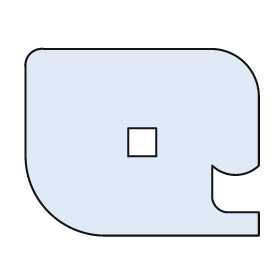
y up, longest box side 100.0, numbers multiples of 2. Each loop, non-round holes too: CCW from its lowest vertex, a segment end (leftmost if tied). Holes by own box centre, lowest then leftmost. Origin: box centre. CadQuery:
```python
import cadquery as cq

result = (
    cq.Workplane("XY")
    .moveTo(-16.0, -40.0)
    .lineTo(50.0, -40.0)
    .lineTo(50.0, -30.0)
    .lineTo(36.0, -30.0)
    .threePointArc((32.0, -28.0), (30.0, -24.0))
    .lineTo(30.0, -10.0)
    .threePointArc((40.0, -14.0), (50.0, -10.0))
    .lineTo(50.0, 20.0)
    .threePointArc((44.0, 34.0), (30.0, 40.0))
    .lineTo(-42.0, 40.0)
    .threePointArc((-48.0, 38.0), (-50.0, 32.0))
    .lineTo(-50.0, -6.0)
    .threePointArc((-40.0, -30.0), (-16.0, -40.0))
    .close()
    .moveTo(-6.0, -6.0)
    .lineTo(6.0, -6.0)
    .lineTo(6.0, 6.0)
    .lineTo(-6.0, 6.0)
    .close()
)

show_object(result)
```